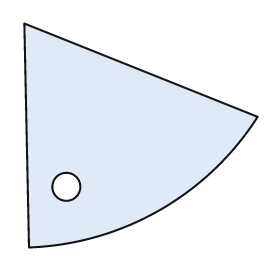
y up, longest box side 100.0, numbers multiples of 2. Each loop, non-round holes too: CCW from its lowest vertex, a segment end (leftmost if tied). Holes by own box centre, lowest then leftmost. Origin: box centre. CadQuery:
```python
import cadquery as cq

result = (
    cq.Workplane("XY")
    .moveTo(-48.0, -48.0)
    .threePointArc((8.0, -32.0), (50.0, 8.0))
    .lineTo(-50.0, 48.0)
    .close()
    .moveTo(-32.0, -22.0)
    .circle(6.0)
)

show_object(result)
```